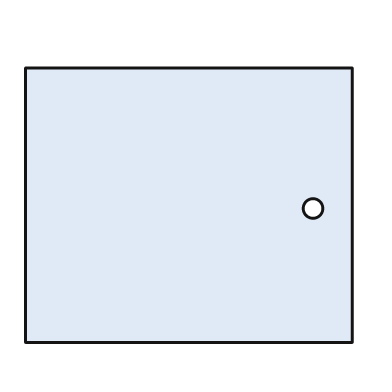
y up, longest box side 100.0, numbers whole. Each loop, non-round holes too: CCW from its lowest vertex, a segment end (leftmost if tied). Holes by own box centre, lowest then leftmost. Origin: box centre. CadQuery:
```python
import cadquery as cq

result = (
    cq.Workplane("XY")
    .moveTo(-50.0, -42.0)
    .lineTo(50.0, -42.0)
    .lineTo(50.0, 42.0)
    .lineTo(-50.0, 42.0)
    .close()
    .moveTo(38.0, -1.0)
    .circle(3.0)
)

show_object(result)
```